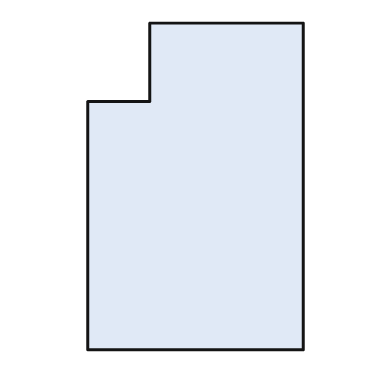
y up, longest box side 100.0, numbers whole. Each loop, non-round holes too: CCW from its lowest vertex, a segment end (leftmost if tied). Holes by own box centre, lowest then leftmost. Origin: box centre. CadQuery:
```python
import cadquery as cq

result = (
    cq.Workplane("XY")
    .moveTo(-33.0, -50.0)
    .lineTo(33.0, -50.0)
    .lineTo(33.0, 50.0)
    .lineTo(-14.0, 50.0)
    .lineTo(-14.0, 26.0)
    .lineTo(-33.0, 26.0)
    .close()
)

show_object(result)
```